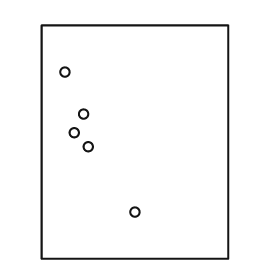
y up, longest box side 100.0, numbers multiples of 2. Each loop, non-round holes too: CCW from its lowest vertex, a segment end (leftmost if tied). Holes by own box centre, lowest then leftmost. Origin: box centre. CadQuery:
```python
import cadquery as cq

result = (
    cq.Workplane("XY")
    .moveTo(-40.0, -50.0)
    .lineTo(40.0, -50.0)
    .lineTo(40.0, 50.0)
    .lineTo(-40.0, 50.0)
    .close()
    .moveTo(0.0, -30.0)
    .circle(2.0)
    .moveTo(-20.0, -2.0)
    .circle(2.0)
    .moveTo(-26.0, 4.0)
    .circle(2.0)
    .moveTo(-22.0, 12.0)
    .circle(2.0)
    .moveTo(-30.0, 30.0)
    .circle(2.0)
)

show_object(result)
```